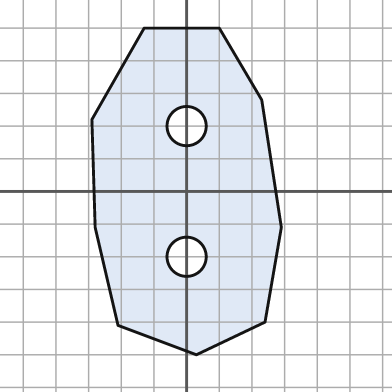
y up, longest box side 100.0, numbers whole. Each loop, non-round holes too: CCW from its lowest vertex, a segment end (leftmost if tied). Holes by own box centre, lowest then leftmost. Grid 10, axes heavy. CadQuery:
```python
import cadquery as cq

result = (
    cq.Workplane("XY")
    .moveTo(3.0, -50.0)
    .lineTo(24.0, -40.0)
    .lineTo(29.0, -11.0)
    .lineTo(23.0, 28.0)
    .lineTo(10.0, 50.0)
    .lineTo(-13.0, 50.0)
    .lineTo(-29.0, 22.0)
    .lineTo(-28.0, -11.0)
    .lineTo(-21.0, -41.0)
    .close()
    .moveTo(0.0, -20.0)
    .circle(6.0)
    .moveTo(0.0, 20.0)
    .circle(6.0)
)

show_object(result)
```